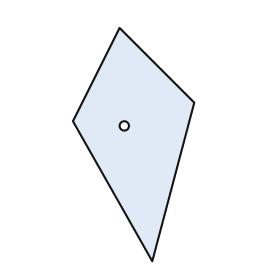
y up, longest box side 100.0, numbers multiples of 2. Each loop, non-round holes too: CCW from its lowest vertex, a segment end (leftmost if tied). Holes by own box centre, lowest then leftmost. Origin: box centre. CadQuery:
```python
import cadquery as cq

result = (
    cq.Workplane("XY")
    .moveTo(8.0, -50.0)
    .lineTo(26.0, 18.0)
    .lineTo(-6.0, 50.0)
    .lineTo(-26.0, 10.0)
    .close()
    .moveTo(-4.0, 8.0)
    .circle(2.0)
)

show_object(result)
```